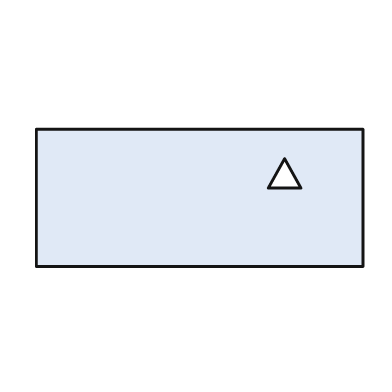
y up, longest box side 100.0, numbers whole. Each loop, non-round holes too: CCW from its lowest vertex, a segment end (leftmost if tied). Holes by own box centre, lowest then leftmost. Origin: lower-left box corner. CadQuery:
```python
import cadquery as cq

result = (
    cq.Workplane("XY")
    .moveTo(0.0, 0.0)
    .lineTo(100.0, 0.0)
    .lineTo(100.0, 42.0)
    .lineTo(0.0, 42.0)
    .close()
    .moveTo(71.0, 24.0)
    .lineTo(81.0, 24.0)
    .lineTo(76.0, 33.0)
    .close()
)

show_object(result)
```